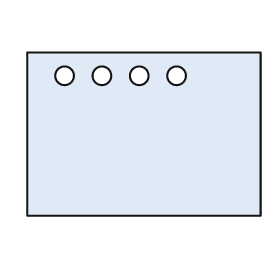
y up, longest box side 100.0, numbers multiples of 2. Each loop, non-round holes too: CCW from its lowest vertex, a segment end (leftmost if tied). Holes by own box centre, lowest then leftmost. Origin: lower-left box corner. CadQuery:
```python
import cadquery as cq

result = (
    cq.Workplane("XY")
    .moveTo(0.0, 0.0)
    .lineTo(100.0, 0.0)
    .lineTo(100.0, 70.0)
    .lineTo(0.0, 70.0)
    .close()
    .moveTo(16.0, 60.0)
    .circle(4.0)
    .moveTo(32.0, 60.0)
    .circle(4.0)
    .moveTo(48.0, 60.0)
    .circle(4.0)
    .moveTo(64.0, 60.0)
    .circle(4.0)
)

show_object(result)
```